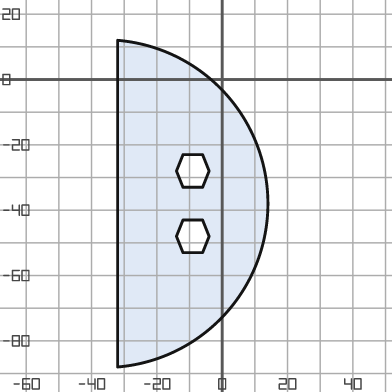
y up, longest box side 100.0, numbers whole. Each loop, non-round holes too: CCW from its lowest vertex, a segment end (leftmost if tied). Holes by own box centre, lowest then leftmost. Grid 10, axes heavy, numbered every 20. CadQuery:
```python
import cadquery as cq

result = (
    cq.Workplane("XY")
    .moveTo(-32.0, -88.0)
    .threePointArc((14.0, -38.0), (-32.0, 12.0))
    .close()
    .moveTo(-12.0, -53.0)
    .lineTo(-6.0, -53.0)
    .lineTo(-4.0, -48.0)
    .lineTo(-6.0, -43.0)
    .lineTo(-12.0, -43.0)
    .lineTo(-14.0, -48.0)
    .close()
    .moveTo(-12.0, -33.0)
    .lineTo(-6.0, -33.0)
    .lineTo(-4.0, -28.0)
    .lineTo(-6.0, -23.0)
    .lineTo(-12.0, -23.0)
    .lineTo(-14.0, -28.0)
    .close()
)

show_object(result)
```